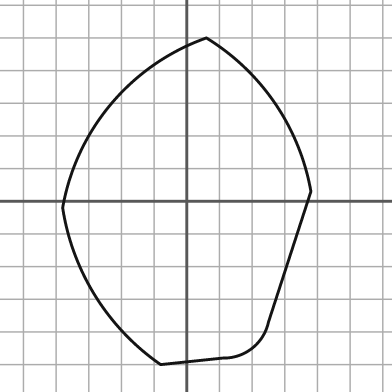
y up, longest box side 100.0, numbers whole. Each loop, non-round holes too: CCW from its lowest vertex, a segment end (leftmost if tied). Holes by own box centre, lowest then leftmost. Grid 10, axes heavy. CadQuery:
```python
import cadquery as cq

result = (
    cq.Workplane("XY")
    .moveTo(-8.0, -50.0)
    .lineTo(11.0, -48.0)
    .threePointArc((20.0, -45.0), (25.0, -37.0))
    .lineTo(38.0, 3.0)
    .threePointArc((27.0, 30.0), (6.0, 50.0))
    .threePointArc((-23.0, 30.0), (-38.0, -2.0))
    .threePointArc((-28.0, -29.0), (-8.0, -50.0))
    .close()
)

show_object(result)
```